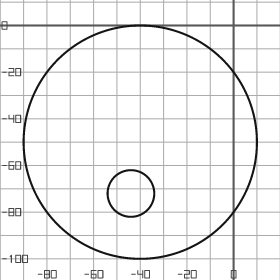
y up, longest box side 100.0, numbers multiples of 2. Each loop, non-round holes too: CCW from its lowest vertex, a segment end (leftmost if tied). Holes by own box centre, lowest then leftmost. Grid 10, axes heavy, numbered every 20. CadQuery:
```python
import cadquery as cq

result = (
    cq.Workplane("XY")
    .moveTo(-40.0, -50.0)
    .circle(50.0)
    .moveTo(-44.0, -72.0)
    .circle(10.0)
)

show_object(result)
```